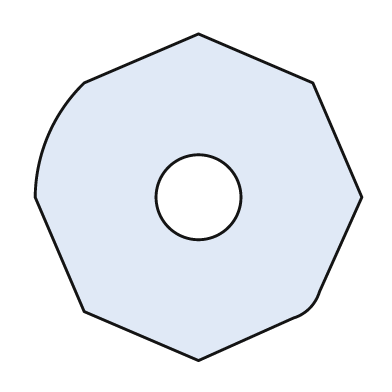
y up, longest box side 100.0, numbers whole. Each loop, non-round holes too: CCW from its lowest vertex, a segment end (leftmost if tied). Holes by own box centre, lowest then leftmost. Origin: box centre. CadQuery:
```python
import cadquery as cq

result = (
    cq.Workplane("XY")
    .moveTo(0.0, -50.0)
    .lineTo(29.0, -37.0)
    .threePointArc((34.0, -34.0), (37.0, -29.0))
    .lineTo(50.0, 0.0)
    .lineTo(35.0, 35.0)
    .lineTo(0.0, 50.0)
    .lineTo(-35.0, 35.0)
    .threePointArc((-46.0, 19.0), (-50.0, 0.0))
    .lineTo(-35.0, -35.0)
    .close()
    .moveTo(0.0, 0.0)
    .circle(13.0)
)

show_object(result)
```